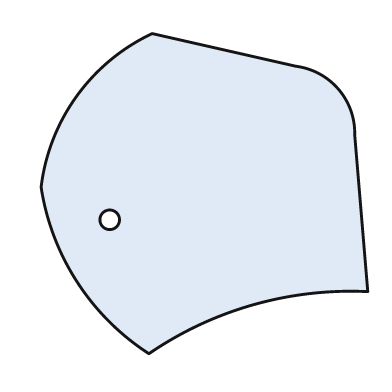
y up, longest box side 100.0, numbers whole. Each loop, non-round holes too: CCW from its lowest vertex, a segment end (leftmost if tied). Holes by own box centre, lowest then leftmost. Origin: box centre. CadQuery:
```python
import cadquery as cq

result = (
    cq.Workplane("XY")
    .moveTo(-17.0, -49.0)
    .threePointArc((15.0, -34.0), (50.0, -30.0))
    .lineTo(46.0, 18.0)
    .threePointArc((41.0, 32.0), (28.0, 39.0))
    .lineTo(-16.0, 49.0)
    .threePointArc((-39.0, 30.0), (-50.0, 2.0))
    .threePointArc((-39.0, -27.0), (-17.0, -49.0))
    .close()
    .moveTo(-29.0, -8.0)
    .circle(3.0)
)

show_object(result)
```